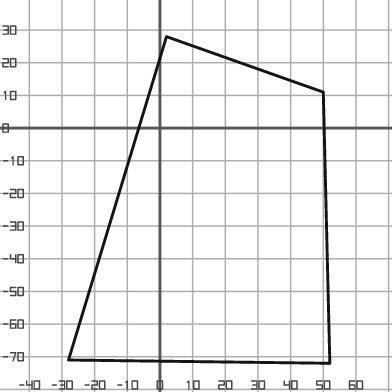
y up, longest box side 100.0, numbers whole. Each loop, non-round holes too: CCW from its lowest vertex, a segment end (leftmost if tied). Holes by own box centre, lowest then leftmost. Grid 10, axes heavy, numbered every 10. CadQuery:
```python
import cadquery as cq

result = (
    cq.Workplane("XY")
    .moveTo(52.0, -72.0)
    .lineTo(50.0, 11.0)
    .lineTo(2.0, 28.0)
    .lineTo(-28.0, -71.0)
    .close()
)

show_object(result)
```